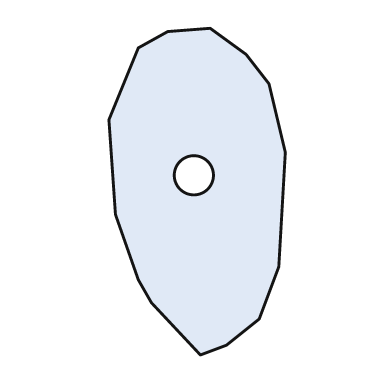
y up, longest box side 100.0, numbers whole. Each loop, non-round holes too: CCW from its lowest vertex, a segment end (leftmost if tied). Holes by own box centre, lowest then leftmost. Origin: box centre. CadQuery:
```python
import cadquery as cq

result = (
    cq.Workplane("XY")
    .moveTo(1.0, -50.0)
    .lineTo(9.0, -47.0)
    .lineTo(19.0, -39.0)
    .lineTo(25.0, -23.0)
    .lineTo(27.0, 12.0)
    .lineTo(22.0, 33.0)
    .lineTo(15.0, 42.0)
    .lineTo(4.0, 50.0)
    .lineTo(-9.0, 49.0)
    .lineTo(-18.0, 44.0)
    .lineTo(-27.0, 22.0)
    .lineTo(-25.0, -7.0)
    .lineTo(-18.0, -27.0)
    .lineTo(-14.0, -34.0)
    .close()
    .moveTo(-1.0, 5.0)
    .circle(6.0)
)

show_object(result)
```